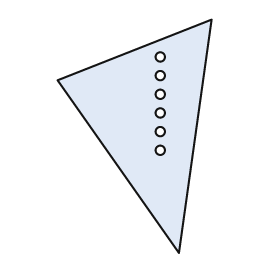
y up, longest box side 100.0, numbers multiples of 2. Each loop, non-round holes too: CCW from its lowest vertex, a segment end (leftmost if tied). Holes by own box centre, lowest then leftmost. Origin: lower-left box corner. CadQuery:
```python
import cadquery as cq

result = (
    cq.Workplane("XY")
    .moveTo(52.0, 0.0)
    .lineTo(66.0, 100.0)
    .lineTo(0.0, 74.0)
    .close()
    .moveTo(44.0, 44.0)
    .circle(2.0)
    .moveTo(44.0, 52.0)
    .circle(2.0)
    .moveTo(44.0, 60.0)
    .circle(2.0)
    .moveTo(44.0, 68.0)
    .circle(2.0)
    .moveTo(44.0, 76.0)
    .circle(2.0)
    .moveTo(44.0, 84.0)
    .circle(2.0)
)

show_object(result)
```